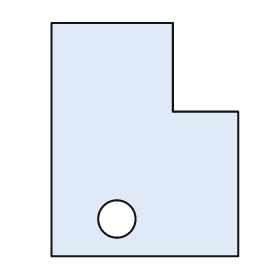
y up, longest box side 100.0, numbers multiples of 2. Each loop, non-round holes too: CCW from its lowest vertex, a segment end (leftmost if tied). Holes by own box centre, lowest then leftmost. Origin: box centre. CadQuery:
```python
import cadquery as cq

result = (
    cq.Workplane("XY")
    .moveTo(-40.0, -50.0)
    .lineTo(40.0, -50.0)
    .lineTo(40.0, 12.0)
    .lineTo(12.0, 12.0)
    .lineTo(12.0, 50.0)
    .lineTo(-40.0, 50.0)
    .close()
    .moveTo(-12.0, -34.0)
    .circle(8.0)
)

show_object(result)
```